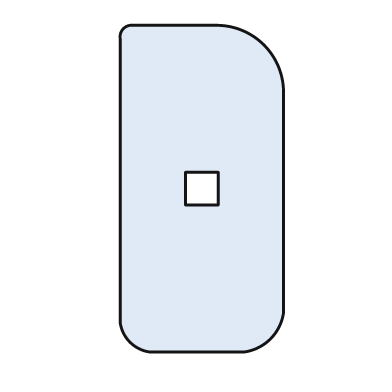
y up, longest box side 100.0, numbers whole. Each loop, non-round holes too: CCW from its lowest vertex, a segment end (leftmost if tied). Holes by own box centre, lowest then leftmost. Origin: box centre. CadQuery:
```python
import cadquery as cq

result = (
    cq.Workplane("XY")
    .moveTo(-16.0, -50.0)
    .lineTo(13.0, -50.0)
    .threePointArc((21.0, -46.0), (25.0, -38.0))
    .lineTo(25.0, 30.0)
    .threePointArc((19.0, 44.0), (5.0, 50.0))
    .lineTo(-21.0, 50.0)
    .threePointArc((-24.0, 49.0), (-25.0, 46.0))
    .lineTo(-25.0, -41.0)
    .threePointArc((-22.0, -47.0), (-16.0, -50.0))
    .close()
    .moveTo(-5.0, -5.0)
    .lineTo(5.0, -5.0)
    .lineTo(5.0, 5.0)
    .lineTo(-5.0, 5.0)
    .close()
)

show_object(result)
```